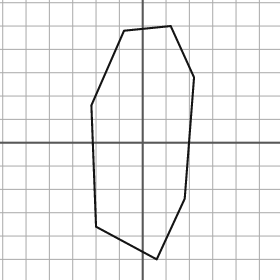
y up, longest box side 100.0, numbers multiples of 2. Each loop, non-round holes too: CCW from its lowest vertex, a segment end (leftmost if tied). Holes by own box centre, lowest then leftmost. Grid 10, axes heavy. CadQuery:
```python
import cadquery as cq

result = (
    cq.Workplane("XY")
    .moveTo(6.0, -50.0)
    .lineTo(18.0, -24.0)
    .lineTo(22.0, 28.0)
    .lineTo(12.0, 50.0)
    .lineTo(-8.0, 48.0)
    .lineTo(-22.0, 16.0)
    .lineTo(-20.0, -36.0)
    .close()
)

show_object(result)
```